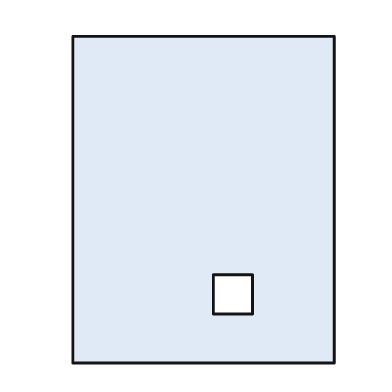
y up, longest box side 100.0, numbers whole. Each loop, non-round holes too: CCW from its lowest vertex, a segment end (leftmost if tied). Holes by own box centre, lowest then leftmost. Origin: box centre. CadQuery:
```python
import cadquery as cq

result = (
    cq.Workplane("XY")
    .moveTo(-40.0, -50.0)
    .lineTo(40.0, -50.0)
    .lineTo(40.0, 50.0)
    .lineTo(-40.0, 50.0)
    .close()
    .moveTo(3.0, -35.0)
    .lineTo(15.0, -35.0)
    .lineTo(15.0, -23.0)
    .lineTo(3.0, -23.0)
    .close()
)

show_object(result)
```